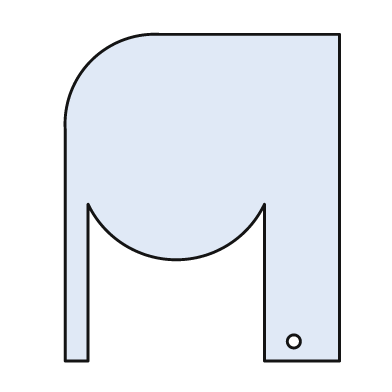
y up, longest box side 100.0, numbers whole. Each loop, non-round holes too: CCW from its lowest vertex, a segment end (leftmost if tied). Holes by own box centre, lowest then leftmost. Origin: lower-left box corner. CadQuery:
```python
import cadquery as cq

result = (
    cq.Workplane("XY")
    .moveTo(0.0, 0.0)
    .lineTo(7.0, 0.0)
    .lineTo(7.0, 48.0)
    .threePointArc((34.0, 31.0), (61.0, 48.0))
    .lineTo(61.0, 0.0)
    .lineTo(84.0, 0.0)
    .lineTo(84.0, 100.0)
    .lineTo(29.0, 100.0)
    .threePointArc((8.0, 92.0), (0.0, 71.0))
    .close()
    .moveTo(70.0, 6.0)
    .circle(2.0)
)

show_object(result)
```